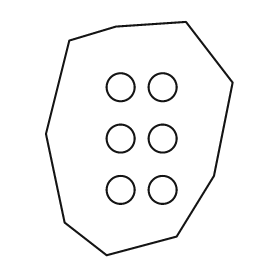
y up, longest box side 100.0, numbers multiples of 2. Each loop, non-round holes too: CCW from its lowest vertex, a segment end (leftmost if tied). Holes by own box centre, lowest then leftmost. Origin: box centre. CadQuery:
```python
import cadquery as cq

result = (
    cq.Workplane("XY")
    .moveTo(-14.0, -50.0)
    .lineTo(16.0, -42.0)
    .lineTo(32.0, -16.0)
    .lineTo(40.0, 24.0)
    .lineTo(20.0, 50.0)
    .lineTo(-10.0, 48.0)
    .lineTo(-30.0, 42.0)
    .lineTo(-40.0, 2.0)
    .lineTo(-32.0, -36.0)
    .close()
    .moveTo(-8.0, -22.0)
    .circle(6.0)
    .moveTo(10.0, -22.0)
    .circle(6.0)
    .moveTo(-8.0, 0.0)
    .circle(6.0)
    .moveTo(10.0, 0.0)
    .circle(6.0)
    .moveTo(-8.0, 22.0)
    .circle(6.0)
    .moveTo(10.0, 22.0)
    .circle(6.0)
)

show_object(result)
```